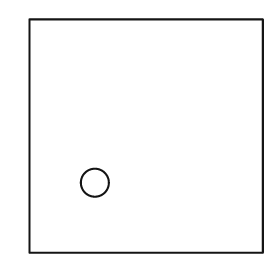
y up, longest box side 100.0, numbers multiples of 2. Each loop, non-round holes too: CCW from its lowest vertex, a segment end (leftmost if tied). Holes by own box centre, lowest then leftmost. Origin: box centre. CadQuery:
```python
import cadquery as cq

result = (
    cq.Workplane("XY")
    .moveTo(-50.0, -50.0)
    .lineTo(50.0, -50.0)
    .lineTo(50.0, 50.0)
    .lineTo(-50.0, 50.0)
    .close()
    .moveTo(-22.0, -20.0)
    .circle(6.0)
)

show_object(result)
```